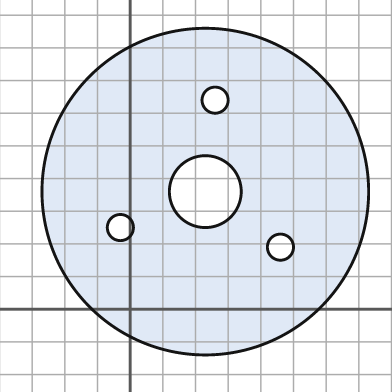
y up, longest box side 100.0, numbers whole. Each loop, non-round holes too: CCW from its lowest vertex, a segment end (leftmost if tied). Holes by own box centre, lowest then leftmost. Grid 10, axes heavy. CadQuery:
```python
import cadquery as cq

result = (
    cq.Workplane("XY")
    .moveTo(23.0, 36.0)
    .circle(50.0)
    .moveTo(46.0, 19.0)
    .circle(4.0)
    .moveTo(-3.0, 25.0)
    .circle(4.0)
    .moveTo(23.0, 36.0)
    .circle(11.0)
    .moveTo(26.0, 64.0)
    .circle(4.0)
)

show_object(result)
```